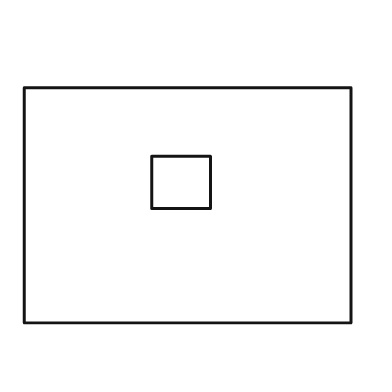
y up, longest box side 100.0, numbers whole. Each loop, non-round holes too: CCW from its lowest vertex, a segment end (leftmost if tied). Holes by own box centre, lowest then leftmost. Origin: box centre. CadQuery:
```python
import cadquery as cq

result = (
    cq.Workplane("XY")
    .moveTo(-50.0, -36.0)
    .lineTo(50.0, -36.0)
    .lineTo(50.0, 36.0)
    .lineTo(-50.0, 36.0)
    .close()
    .moveTo(-11.0, -1.0)
    .lineTo(7.0, -1.0)
    .lineTo(7.0, 15.0)
    .lineTo(-11.0, 15.0)
    .close()
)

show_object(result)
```